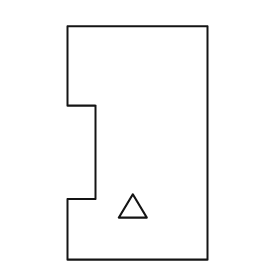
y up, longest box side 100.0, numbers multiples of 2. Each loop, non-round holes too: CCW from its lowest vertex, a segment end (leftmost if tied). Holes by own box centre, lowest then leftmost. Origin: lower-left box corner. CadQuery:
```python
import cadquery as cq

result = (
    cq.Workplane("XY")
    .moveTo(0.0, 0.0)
    .lineTo(60.0, 0.0)
    .lineTo(60.0, 100.0)
    .lineTo(0.0, 100.0)
    .lineTo(0.0, 66.0)
    .lineTo(12.0, 66.0)
    .lineTo(12.0, 26.0)
    .lineTo(0.0, 26.0)
    .close()
    .moveTo(22.0, 18.0)
    .lineTo(34.0, 18.0)
    .lineTo(28.0, 28.0)
    .close()
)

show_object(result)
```